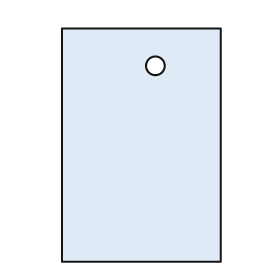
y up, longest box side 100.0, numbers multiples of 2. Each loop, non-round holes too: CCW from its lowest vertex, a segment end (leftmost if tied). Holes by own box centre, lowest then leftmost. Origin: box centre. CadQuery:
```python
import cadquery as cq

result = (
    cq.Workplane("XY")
    .moveTo(-34.0, -50.0)
    .lineTo(34.0, -50.0)
    .lineTo(34.0, 50.0)
    .lineTo(-34.0, 50.0)
    .close()
    .moveTo(6.0, 34.0)
    .circle(4.0)
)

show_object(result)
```